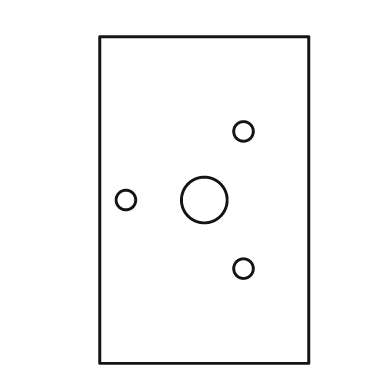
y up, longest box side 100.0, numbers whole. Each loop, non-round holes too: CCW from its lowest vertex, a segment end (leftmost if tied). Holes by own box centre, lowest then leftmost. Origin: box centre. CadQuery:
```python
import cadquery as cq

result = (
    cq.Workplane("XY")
    .moveTo(-32.0, -50.0)
    .lineTo(32.0, -50.0)
    .lineTo(32.0, 50.0)
    .lineTo(-32.0, 50.0)
    .close()
    .moveTo(12.0, -21.0)
    .circle(3.0)
    .moveTo(-24.0, 0.0)
    .circle(3.0)
    .moveTo(0.0, 0.0)
    .circle(7.0)
    .moveTo(12.0, 21.0)
    .circle(3.0)
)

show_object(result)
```